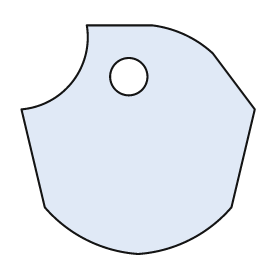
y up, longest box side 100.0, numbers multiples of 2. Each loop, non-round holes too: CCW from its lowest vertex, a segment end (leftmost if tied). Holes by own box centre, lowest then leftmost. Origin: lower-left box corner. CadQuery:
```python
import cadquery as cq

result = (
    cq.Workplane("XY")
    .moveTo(50.0, 0.0)
    .threePointArc((72.0, 6.0), (90.0, 20.0))
    .lineTo(100.0, 62.0)
    .lineTo(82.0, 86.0)
    .threePointArc((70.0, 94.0), (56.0, 98.0))
    .lineTo(28.0, 98.0)
    .threePointArc((22.0, 74.0), (0.0, 62.0))
    .lineTo(10.0, 20.0)
    .threePointArc((28.0, 6.0), (50.0, 0.0))
    .close()
    .moveTo(46.0, 76.0)
    .circle(8.0)
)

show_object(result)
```